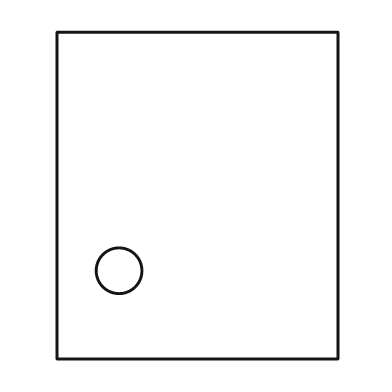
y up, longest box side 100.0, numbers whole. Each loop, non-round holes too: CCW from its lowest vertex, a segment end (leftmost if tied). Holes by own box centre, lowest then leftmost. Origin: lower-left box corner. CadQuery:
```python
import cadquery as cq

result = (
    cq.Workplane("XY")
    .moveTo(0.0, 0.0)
    .lineTo(86.0, 0.0)
    .lineTo(86.0, 100.0)
    .lineTo(0.0, 100.0)
    .close()
    .moveTo(19.0, 27.0)
    .circle(7.0)
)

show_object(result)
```